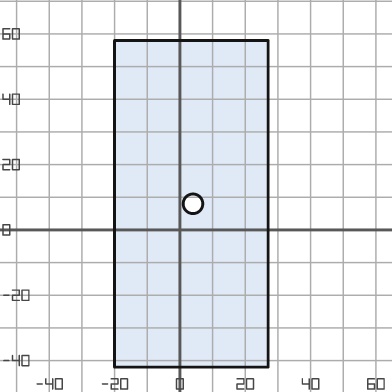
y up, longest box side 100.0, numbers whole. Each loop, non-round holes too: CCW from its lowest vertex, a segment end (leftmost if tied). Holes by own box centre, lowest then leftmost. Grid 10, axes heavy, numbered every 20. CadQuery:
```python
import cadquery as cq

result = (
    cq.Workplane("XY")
    .moveTo(-20.0, -42.0)
    .lineTo(27.0, -42.0)
    .lineTo(27.0, 58.0)
    .lineTo(-20.0, 58.0)
    .close()
    .moveTo(4.0, 8.0)
    .circle(3.0)
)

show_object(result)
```